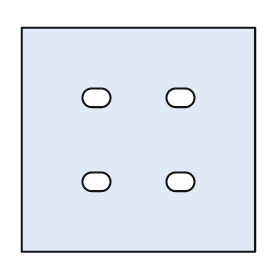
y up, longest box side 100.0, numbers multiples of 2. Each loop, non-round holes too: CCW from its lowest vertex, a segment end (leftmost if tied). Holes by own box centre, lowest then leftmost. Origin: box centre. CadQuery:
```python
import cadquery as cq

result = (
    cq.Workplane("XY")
    .moveTo(-50.0, -48.0)
    .lineTo(50.0, -48.0)
    .lineTo(50.0, 48.0)
    .lineTo(-50.0, 48.0)
    .close()
    .moveTo(-20.0, -22.0)
    .lineTo(-16.0, -22.0)
    .threePointArc((-12.0, -18.0), (-16.0, -14.0))
    .lineTo(-20.0, -14.0)
    .threePointArc((-24.0, -18.0), (-20.0, -22.0))
    .close()
    .moveTo(16.0, -22.0)
    .lineTo(20.0, -22.0)
    .threePointArc((24.0, -18.0), (20.0, -14.0))
    .lineTo(16.0, -14.0)
    .threePointArc((12.0, -18.0), (16.0, -22.0))
    .close()
    .moveTo(-20.0, 14.0)
    .lineTo(-16.0, 14.0)
    .threePointArc((-12.0, 18.0), (-16.0, 22.0))
    .lineTo(-20.0, 22.0)
    .threePointArc((-24.0, 18.0), (-20.0, 14.0))
    .close()
    .moveTo(16.0, 14.0)
    .lineTo(20.0, 14.0)
    .threePointArc((24.0, 18.0), (20.0, 22.0))
    .lineTo(16.0, 22.0)
    .threePointArc((12.0, 18.0), (16.0, 14.0))
    .close()
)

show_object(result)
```